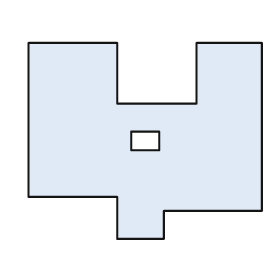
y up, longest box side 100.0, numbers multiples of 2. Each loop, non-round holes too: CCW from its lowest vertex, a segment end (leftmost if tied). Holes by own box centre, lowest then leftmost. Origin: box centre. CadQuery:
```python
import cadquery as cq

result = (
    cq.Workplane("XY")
    .moveTo(-12.0, -42.0)
    .lineTo(8.0, -42.0)
    .lineTo(8.0, -30.0)
    .lineTo(50.0, -30.0)
    .lineTo(50.0, 42.0)
    .lineTo(22.0, 42.0)
    .lineTo(22.0, 16.0)
    .lineTo(-12.0, 16.0)
    .lineTo(-12.0, 42.0)
    .lineTo(-50.0, 42.0)
    .lineTo(-50.0, -24.0)
    .lineTo(-12.0, -24.0)
    .close()
    .moveTo(-6.0, -4.0)
    .lineTo(6.0, -4.0)
    .lineTo(6.0, 4.0)
    .lineTo(-6.0, 4.0)
    .close()
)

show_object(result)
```